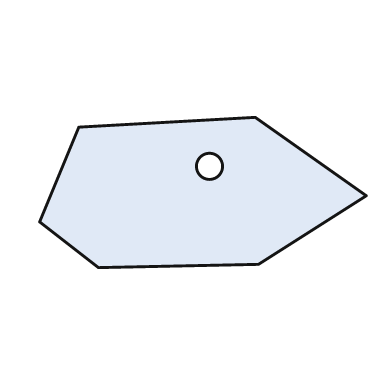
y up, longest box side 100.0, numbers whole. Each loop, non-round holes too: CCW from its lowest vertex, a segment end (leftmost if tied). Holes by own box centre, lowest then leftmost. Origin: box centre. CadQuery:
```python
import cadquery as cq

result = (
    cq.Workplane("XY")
    .moveTo(-32.0, -23.0)
    .lineTo(17.0, -22.0)
    .lineTo(50.0, -1.0)
    .lineTo(16.0, 23.0)
    .lineTo(-38.0, 20.0)
    .lineTo(-50.0, -9.0)
    .close()
    .moveTo(2.0, 8.0)
    .circle(4.0)
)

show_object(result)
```